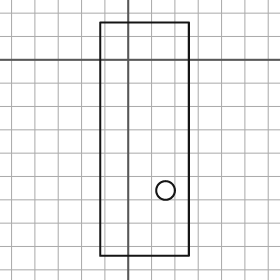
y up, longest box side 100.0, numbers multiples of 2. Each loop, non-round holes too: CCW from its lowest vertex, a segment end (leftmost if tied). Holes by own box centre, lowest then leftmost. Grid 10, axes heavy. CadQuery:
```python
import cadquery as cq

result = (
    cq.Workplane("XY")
    .moveTo(-12.0, -84.0)
    .lineTo(26.0, -84.0)
    .lineTo(26.0, 16.0)
    .lineTo(-12.0, 16.0)
    .close()
    .moveTo(16.0, -56.0)
    .circle(4.0)
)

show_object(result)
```